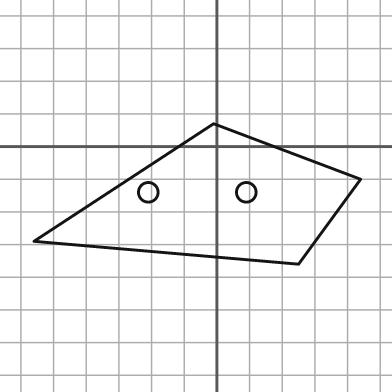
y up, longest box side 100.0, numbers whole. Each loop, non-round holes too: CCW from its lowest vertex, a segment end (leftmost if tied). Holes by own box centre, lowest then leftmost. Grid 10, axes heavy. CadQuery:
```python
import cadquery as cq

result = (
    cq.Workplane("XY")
    .moveTo(25.0, -36.0)
    .lineTo(44.0, -10.0)
    .lineTo(-1.0, 7.0)
    .lineTo(-56.0, -29.0)
    .close()
    .moveTo(-21.0, -14.0)
    .circle(3.0)
    .moveTo(9.0, -14.0)
    .circle(3.0)
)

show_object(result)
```